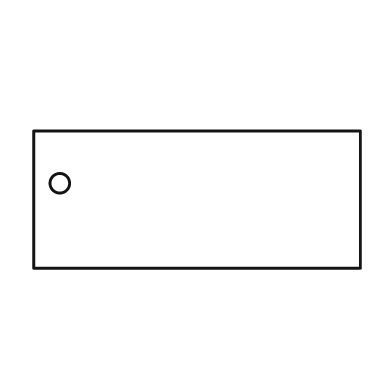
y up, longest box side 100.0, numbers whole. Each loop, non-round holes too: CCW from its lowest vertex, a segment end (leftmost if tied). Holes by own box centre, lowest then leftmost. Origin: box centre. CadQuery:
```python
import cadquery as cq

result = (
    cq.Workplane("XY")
    .moveTo(-50.0, -21.0)
    .lineTo(50.0, -21.0)
    .lineTo(50.0, 21.0)
    .lineTo(-50.0, 21.0)
    .close()
    .moveTo(-42.0, 5.0)
    .circle(3.0)
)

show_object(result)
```